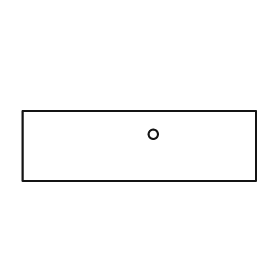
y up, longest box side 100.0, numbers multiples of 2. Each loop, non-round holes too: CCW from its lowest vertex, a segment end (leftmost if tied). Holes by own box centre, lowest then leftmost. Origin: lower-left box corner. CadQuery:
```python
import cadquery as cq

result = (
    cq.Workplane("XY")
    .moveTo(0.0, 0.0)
    .lineTo(100.0, 0.0)
    .lineTo(100.0, 30.0)
    .lineTo(0.0, 30.0)
    .close()
    .moveTo(56.0, 20.0)
    .circle(2.0)
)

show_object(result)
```